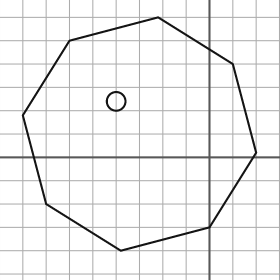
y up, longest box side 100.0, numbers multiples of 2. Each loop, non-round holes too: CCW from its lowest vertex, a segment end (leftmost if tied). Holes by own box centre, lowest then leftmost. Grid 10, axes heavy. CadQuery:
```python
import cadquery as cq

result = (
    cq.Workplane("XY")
    .moveTo(-38.0, -40.0)
    .lineTo(0.0, -30.0)
    .lineTo(20.0, 2.0)
    .lineTo(10.0, 40.0)
    .lineTo(-22.0, 60.0)
    .lineTo(-60.0, 50.0)
    .lineTo(-80.0, 18.0)
    .lineTo(-70.0, -20.0)
    .close()
    .moveTo(-40.0, 24.0)
    .circle(4.0)
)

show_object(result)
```